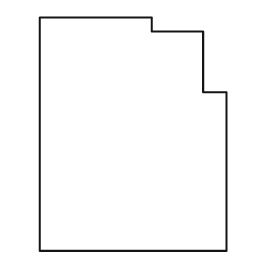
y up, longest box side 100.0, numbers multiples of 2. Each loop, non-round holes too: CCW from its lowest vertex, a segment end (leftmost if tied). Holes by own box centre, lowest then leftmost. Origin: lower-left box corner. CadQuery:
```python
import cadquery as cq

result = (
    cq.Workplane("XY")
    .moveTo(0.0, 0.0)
    .lineTo(80.0, 0.0)
    .lineTo(80.0, 68.0)
    .lineTo(70.0, 68.0)
    .lineTo(70.0, 94.0)
    .lineTo(48.0, 94.0)
    .lineTo(48.0, 100.0)
    .lineTo(0.0, 100.0)
    .close()
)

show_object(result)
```